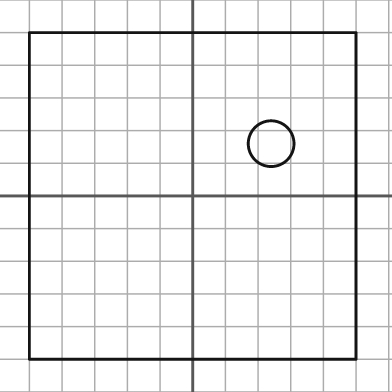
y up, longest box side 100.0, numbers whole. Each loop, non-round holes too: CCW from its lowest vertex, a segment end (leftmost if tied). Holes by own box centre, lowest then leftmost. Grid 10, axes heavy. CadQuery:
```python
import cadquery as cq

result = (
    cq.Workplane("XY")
    .moveTo(-50.0, -50.0)
    .lineTo(50.0, -50.0)
    .lineTo(50.0, 50.0)
    .lineTo(-50.0, 50.0)
    .close()
    .moveTo(24.0, 16.0)
    .circle(7.0)
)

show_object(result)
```